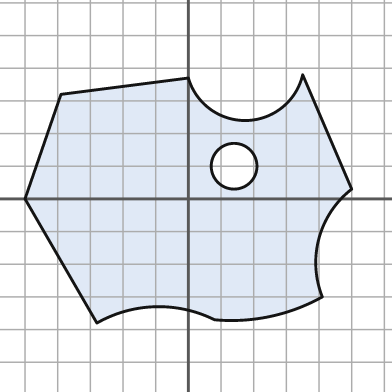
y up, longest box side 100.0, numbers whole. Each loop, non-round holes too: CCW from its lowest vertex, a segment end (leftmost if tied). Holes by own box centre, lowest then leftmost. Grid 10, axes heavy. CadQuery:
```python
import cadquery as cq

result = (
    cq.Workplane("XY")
    .moveTo(-28.0, -38.0)
    .threePointArc((-10.0, -33.0), (8.0, -37.0))
    .threePointArc((25.0, -36.0), (41.0, -30.0))
    .threePointArc((40.0, -12.0), (50.0, 3.0))
    .lineTo(35.0, 38.0)
    .threePointArc((18.0, 24.0), (0.0, 37.0))
    .lineTo(-39.0, 32.0)
    .lineTo(-50.0, 0.0)
    .close()
    .moveTo(14.0, 10.0)
    .circle(7.0)
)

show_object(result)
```